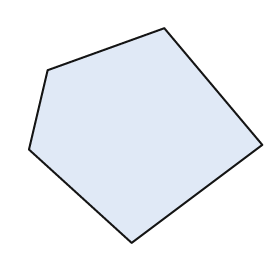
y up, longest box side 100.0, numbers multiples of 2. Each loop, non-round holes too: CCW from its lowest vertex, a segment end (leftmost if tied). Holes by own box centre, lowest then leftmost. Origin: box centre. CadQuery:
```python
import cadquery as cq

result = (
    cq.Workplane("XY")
    .moveTo(-6.0, -46.0)
    .lineTo(50.0, -4.0)
    .lineTo(8.0, 46.0)
    .lineTo(-42.0, 28.0)
    .lineTo(-50.0, -6.0)
    .close()
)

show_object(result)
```